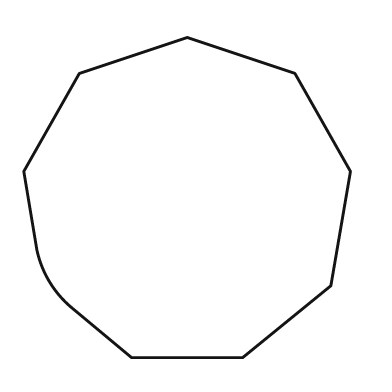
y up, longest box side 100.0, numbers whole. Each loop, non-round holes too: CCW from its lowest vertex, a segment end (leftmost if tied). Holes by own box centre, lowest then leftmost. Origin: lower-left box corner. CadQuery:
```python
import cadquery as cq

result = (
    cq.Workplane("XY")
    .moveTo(33.0, 0.0)
    .lineTo(67.0, 0.0)
    .lineTo(94.0, 22.0)
    .lineTo(100.0, 57.0)
    .lineTo(83.0, 87.0)
    .lineTo(50.0, 98.0)
    .lineTo(17.0, 87.0)
    .lineTo(0.0, 57.0)
    .lineTo(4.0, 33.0)
    .threePointArc((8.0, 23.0), (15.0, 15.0))
    .close()
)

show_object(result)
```